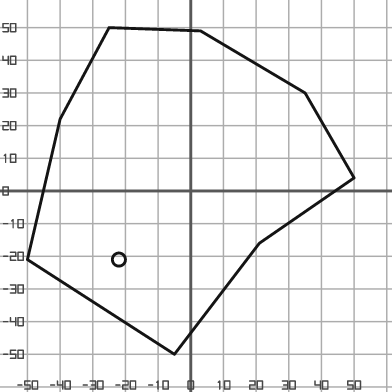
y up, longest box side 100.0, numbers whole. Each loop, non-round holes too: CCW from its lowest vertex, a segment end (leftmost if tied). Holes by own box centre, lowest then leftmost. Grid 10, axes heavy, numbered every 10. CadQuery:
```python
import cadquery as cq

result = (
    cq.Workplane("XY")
    .moveTo(-5.0, -50.0)
    .lineTo(21.0, -16.0)
    .lineTo(50.0, 4.0)
    .lineTo(35.0, 30.0)
    .lineTo(3.0, 49.0)
    .lineTo(-25.0, 50.0)
    .lineTo(-40.0, 22.0)
    .lineTo(-50.0, -21.0)
    .close()
    .moveTo(-22.0, -21.0)
    .circle(2.0)
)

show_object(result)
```